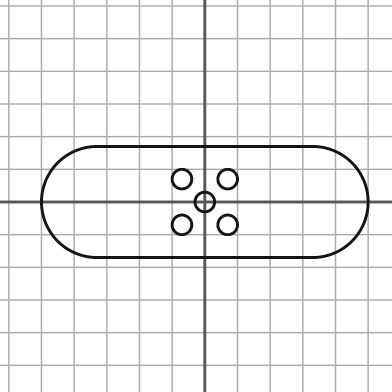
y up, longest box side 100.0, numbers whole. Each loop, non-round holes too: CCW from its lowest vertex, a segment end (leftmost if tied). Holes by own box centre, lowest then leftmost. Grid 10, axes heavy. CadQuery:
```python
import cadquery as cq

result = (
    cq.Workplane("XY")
    .moveTo(-33.0, -17.0)
    .lineTo(33.0, -17.0)
    .threePointArc((50.0, 0.0), (33.0, 17.0))
    .lineTo(-33.0, 17.0)
    .threePointArc((-50.0, 0.0), (-33.0, -17.0))
    .close()
    .moveTo(-7.0, -7.0)
    .circle(3.0)
    .moveTo(7.0, -7.0)
    .circle(3.0)
    .moveTo(0.0, 0.0)
    .circle(3.0)
    .moveTo(-7.0, 7.0)
    .circle(3.0)
    .moveTo(7.0, 7.0)
    .circle(3.0)
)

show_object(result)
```